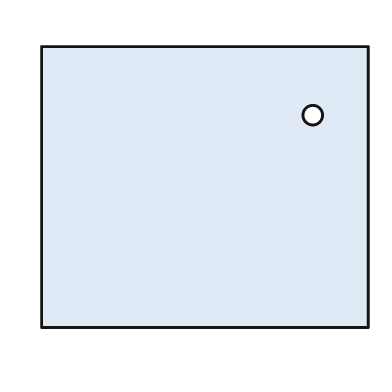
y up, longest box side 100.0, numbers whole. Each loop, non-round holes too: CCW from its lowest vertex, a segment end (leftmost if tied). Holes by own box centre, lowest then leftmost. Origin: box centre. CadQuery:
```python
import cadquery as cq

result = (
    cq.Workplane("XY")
    .moveTo(-50.0, -43.0)
    .lineTo(50.0, -43.0)
    .lineTo(50.0, 43.0)
    .lineTo(-50.0, 43.0)
    .close()
    .moveTo(33.0, 22.0)
    .circle(3.0)
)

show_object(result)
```